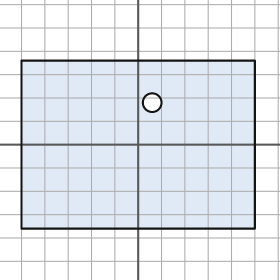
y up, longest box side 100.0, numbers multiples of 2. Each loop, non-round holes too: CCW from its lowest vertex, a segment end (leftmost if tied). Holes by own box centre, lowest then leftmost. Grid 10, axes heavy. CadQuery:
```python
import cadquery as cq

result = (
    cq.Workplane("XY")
    .moveTo(-50.0, -36.0)
    .lineTo(50.0, -36.0)
    .lineTo(50.0, 36.0)
    .lineTo(-50.0, 36.0)
    .close()
    .moveTo(6.0, 18.0)
    .circle(4.0)
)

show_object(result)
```